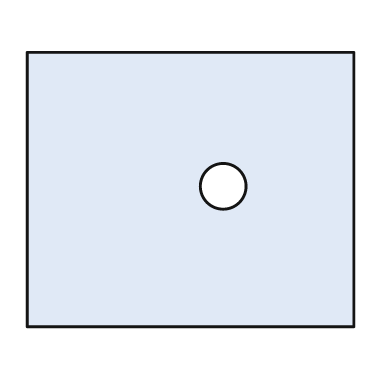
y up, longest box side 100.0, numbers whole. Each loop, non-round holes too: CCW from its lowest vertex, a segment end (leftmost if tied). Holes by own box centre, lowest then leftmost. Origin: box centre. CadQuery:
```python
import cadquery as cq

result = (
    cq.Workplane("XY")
    .moveTo(-50.0, -42.0)
    .lineTo(50.0, -42.0)
    .lineTo(50.0, 42.0)
    .lineTo(-50.0, 42.0)
    .close()
    .moveTo(10.0, 1.0)
    .circle(7.0)
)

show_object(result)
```